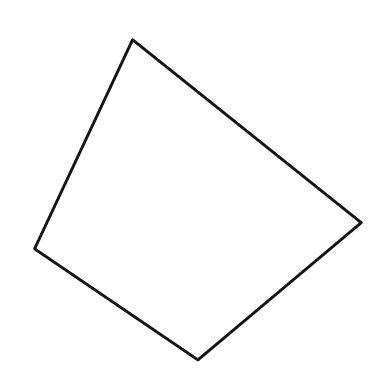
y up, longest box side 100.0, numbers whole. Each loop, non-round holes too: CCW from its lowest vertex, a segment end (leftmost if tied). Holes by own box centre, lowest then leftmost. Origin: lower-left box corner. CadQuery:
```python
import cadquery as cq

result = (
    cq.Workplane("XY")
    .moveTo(50.0, 0.0)
    .lineTo(100.0, 42.0)
    .lineTo(30.0, 98.0)
    .lineTo(0.0, 34.0)
    .close()
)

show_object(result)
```